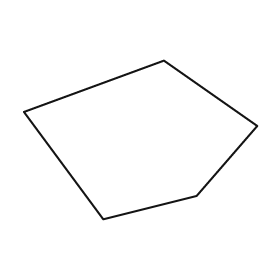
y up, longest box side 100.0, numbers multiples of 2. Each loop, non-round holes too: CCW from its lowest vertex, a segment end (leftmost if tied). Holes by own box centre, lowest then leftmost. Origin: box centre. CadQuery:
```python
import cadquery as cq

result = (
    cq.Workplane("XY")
    .moveTo(-16.0, -34.0)
    .lineTo(24.0, -24.0)
    .lineTo(50.0, 6.0)
    .lineTo(10.0, 34.0)
    .lineTo(-50.0, 12.0)
    .close()
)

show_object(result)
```